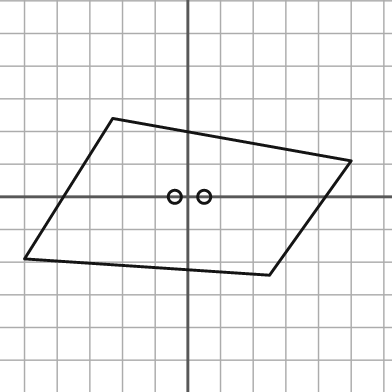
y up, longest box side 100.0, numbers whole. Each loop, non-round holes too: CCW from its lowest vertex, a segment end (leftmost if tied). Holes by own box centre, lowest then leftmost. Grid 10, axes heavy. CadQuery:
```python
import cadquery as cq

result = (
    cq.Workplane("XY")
    .moveTo(25.0, -24.0)
    .lineTo(50.0, 11.0)
    .lineTo(-23.0, 24.0)
    .lineTo(-50.0, -19.0)
    .close()
    .moveTo(-4.0, 0.0)
    .circle(2.0)
    .moveTo(5.0, 0.0)
    .circle(2.0)
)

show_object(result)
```